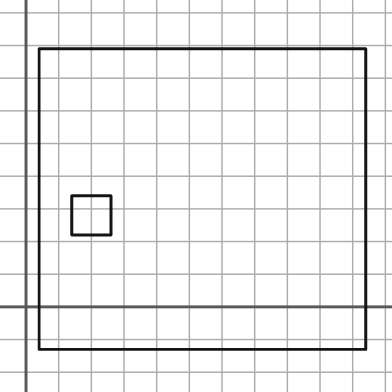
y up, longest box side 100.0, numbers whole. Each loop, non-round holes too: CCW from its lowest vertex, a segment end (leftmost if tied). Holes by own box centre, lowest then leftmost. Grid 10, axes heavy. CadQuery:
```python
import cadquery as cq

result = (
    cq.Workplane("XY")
    .moveTo(4.0, -13.0)
    .lineTo(104.0, -13.0)
    .lineTo(104.0, 79.0)
    .lineTo(4.0, 79.0)
    .close()
    .moveTo(14.0, 22.0)
    .lineTo(26.0, 22.0)
    .lineTo(26.0, 34.0)
    .lineTo(14.0, 34.0)
    .close()
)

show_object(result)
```